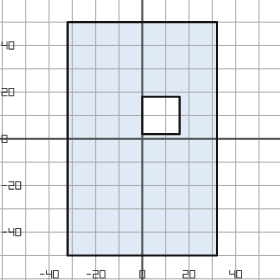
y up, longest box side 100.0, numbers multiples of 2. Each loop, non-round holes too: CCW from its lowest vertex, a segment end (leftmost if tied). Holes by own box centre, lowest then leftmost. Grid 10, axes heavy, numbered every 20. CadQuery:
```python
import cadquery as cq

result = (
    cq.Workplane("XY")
    .moveTo(-32.0, -50.0)
    .lineTo(32.0, -50.0)
    .lineTo(32.0, 50.0)
    .lineTo(-32.0, 50.0)
    .close()
    .moveTo(0.0, 2.0)
    .lineTo(16.0, 2.0)
    .lineTo(16.0, 18.0)
    .lineTo(0.0, 18.0)
    .close()
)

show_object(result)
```